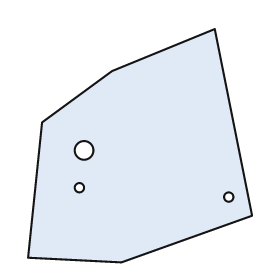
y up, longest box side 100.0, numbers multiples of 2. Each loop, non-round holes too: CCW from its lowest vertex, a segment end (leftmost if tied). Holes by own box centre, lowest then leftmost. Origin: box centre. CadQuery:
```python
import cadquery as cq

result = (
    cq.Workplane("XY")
    .moveTo(-8.0, -50.0)
    .lineTo(48.0, -30.0)
    .lineTo(32.0, 50.0)
    .lineTo(-12.0, 32.0)
    .lineTo(-42.0, 10.0)
    .lineTo(-48.0, -48.0)
    .close()
    .moveTo(38.0, -22.0)
    .circle(2.0)
    .moveTo(-26.0, -18.0)
    .circle(2.0)
    .moveTo(-24.0, -2.0)
    .circle(4.0)
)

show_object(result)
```